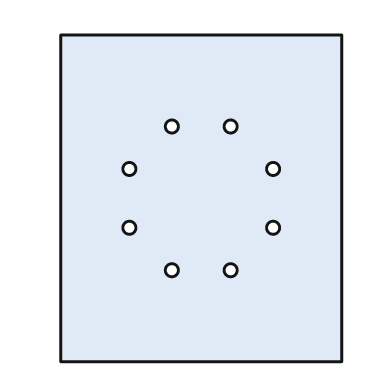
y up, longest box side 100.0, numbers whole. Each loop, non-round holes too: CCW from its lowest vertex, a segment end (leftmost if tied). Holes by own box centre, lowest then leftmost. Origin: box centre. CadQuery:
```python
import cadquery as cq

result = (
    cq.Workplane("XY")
    .moveTo(-43.0, -50.0)
    .lineTo(43.0, -50.0)
    .lineTo(43.0, 50.0)
    .lineTo(-43.0, 50.0)
    .close()
    .moveTo(-9.0, -22.0)
    .circle(2.0)
    .moveTo(9.0, -22.0)
    .circle(2.0)
    .moveTo(-22.0, -9.0)
    .circle(2.0)
    .moveTo(22.0, -9.0)
    .circle(2.0)
    .moveTo(-22.0, 9.0)
    .circle(2.0)
    .moveTo(22.0, 9.0)
    .circle(2.0)
    .moveTo(-9.0, 22.0)
    .circle(2.0)
    .moveTo(9.0, 22.0)
    .circle(2.0)
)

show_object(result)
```